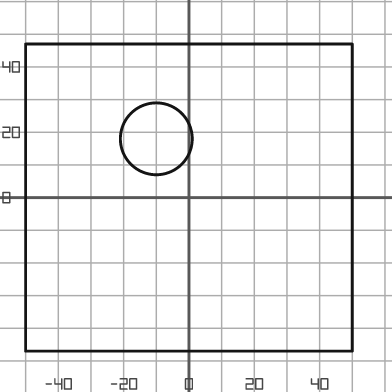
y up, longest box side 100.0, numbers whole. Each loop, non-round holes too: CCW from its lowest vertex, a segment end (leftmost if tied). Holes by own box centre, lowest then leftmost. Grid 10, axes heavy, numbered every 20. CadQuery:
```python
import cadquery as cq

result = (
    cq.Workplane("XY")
    .moveTo(-50.0, -47.0)
    .lineTo(50.0, -47.0)
    .lineTo(50.0, 47.0)
    .lineTo(-50.0, 47.0)
    .close()
    .moveTo(-10.0, 18.0)
    .circle(11.0)
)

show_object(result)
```